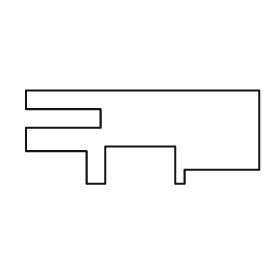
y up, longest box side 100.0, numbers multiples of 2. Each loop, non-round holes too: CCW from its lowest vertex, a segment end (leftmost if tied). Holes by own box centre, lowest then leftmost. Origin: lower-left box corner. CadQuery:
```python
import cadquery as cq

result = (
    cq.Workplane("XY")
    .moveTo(26.0, 0.0)
    .lineTo(34.0, 0.0)
    .lineTo(34.0, 16.0)
    .lineTo(64.0, 16.0)
    .lineTo(64.0, 0.0)
    .lineTo(68.0, 0.0)
    .lineTo(68.0, 6.0)
    .lineTo(100.0, 6.0)
    .lineTo(100.0, 40.0)
    .lineTo(0.0, 40.0)
    .lineTo(0.0, 32.0)
    .lineTo(32.0, 32.0)
    .lineTo(32.0, 24.0)
    .lineTo(0.0, 24.0)
    .lineTo(0.0, 14.0)
    .lineTo(26.0, 14.0)
    .close()
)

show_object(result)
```